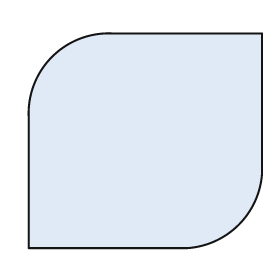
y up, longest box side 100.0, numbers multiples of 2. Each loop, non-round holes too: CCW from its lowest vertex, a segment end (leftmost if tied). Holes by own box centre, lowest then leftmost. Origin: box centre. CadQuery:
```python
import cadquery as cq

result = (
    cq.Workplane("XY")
    .moveTo(-50.0, -46.0)
    .lineTo(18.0, -46.0)
    .threePointArc((40.0, -36.0), (50.0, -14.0))
    .lineTo(50.0, 46.0)
    .lineTo(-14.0, 46.0)
    .threePointArc((-40.0, 36.0), (-50.0, 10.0))
    .close()
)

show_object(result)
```